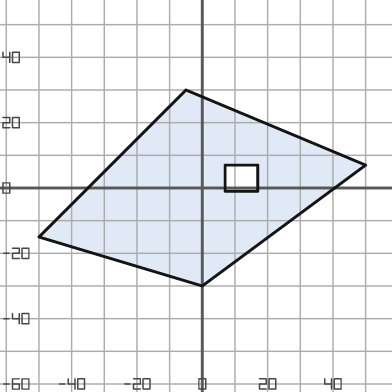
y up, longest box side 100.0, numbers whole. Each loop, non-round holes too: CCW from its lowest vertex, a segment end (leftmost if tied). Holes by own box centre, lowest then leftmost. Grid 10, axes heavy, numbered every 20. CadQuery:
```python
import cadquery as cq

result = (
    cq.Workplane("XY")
    .moveTo(0.0, -30.0)
    .lineTo(50.0, 7.0)
    .lineTo(-5.0, 30.0)
    .lineTo(-50.0, -15.0)
    .close()
    .moveTo(7.0, -1.0)
    .lineTo(17.0, -1.0)
    .lineTo(17.0, 7.0)
    .lineTo(7.0, 7.0)
    .close()
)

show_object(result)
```